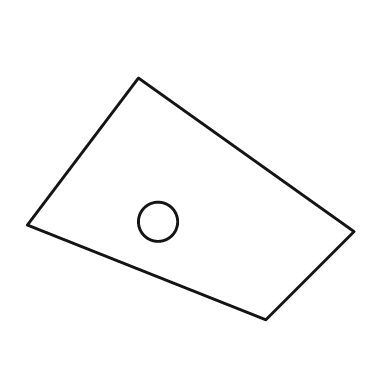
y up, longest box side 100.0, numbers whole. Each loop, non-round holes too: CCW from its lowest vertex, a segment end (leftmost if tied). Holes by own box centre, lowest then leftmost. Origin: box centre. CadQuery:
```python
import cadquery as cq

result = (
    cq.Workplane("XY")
    .moveTo(23.0, -37.0)
    .lineTo(50.0, -10.0)
    .lineTo(-16.0, 37.0)
    .lineTo(-50.0, -8.0)
    .close()
    .moveTo(-10.0, -7.0)
    .circle(6.0)
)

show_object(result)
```